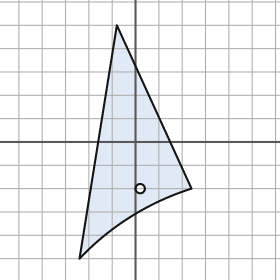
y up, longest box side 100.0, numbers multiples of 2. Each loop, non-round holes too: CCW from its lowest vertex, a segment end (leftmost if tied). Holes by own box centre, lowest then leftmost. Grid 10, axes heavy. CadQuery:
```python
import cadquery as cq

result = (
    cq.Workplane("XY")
    .moveTo(-24.0, -50.0)
    .threePointArc((-2.0, -32.0), (24.0, -20.0))
    .lineTo(-8.0, 50.0)
    .close()
    .moveTo(2.0, -20.0)
    .circle(2.0)
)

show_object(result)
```